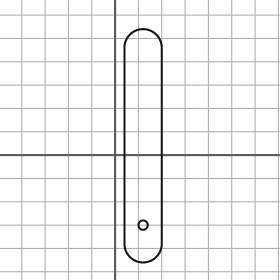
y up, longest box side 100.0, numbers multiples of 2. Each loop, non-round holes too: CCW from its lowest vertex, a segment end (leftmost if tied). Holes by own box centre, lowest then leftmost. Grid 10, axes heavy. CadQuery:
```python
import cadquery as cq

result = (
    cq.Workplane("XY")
    .moveTo(4.0, -38.0)
    .threePointArc((12.0, -46.0), (20.0, -38.0))
    .lineTo(20.0, 46.0)
    .threePointArc((12.0, 54.0), (4.0, 46.0))
    .close()
    .moveTo(12.0, -30.0)
    .circle(2.0)
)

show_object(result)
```